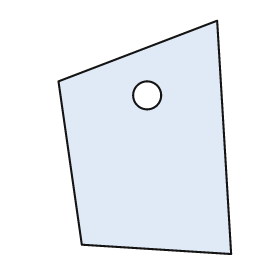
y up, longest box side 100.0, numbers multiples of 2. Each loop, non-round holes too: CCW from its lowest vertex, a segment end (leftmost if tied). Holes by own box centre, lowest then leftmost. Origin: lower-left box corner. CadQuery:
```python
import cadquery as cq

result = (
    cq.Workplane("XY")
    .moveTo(74.0, 0.0)
    .lineTo(68.0, 100.0)
    .lineTo(0.0, 74.0)
    .lineTo(10.0, 4.0)
    .close()
    .moveTo(38.0, 68.0)
    .circle(6.0)
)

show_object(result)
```